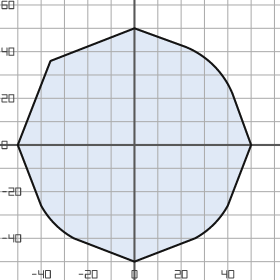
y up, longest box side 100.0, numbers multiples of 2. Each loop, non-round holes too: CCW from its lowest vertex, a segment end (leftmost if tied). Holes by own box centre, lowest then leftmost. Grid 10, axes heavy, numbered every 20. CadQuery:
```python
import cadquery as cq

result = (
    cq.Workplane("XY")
    .moveTo(0.0, -50.0)
    .lineTo(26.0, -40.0)
    .threePointArc((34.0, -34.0), (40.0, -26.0))
    .lineTo(50.0, 0.0)
    .lineTo(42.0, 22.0)
    .threePointArc((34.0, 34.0), (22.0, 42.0))
    .lineTo(0.0, 50.0)
    .lineTo(-36.0, 36.0)
    .lineTo(-50.0, 0.0)
    .lineTo(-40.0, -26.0)
    .threePointArc((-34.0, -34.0), (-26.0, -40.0))
    .close()
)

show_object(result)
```